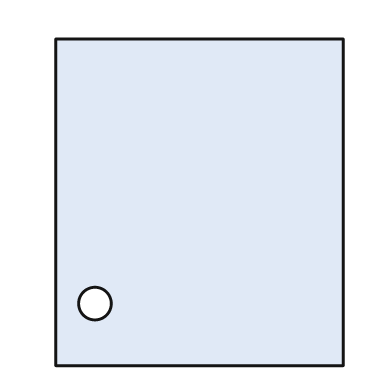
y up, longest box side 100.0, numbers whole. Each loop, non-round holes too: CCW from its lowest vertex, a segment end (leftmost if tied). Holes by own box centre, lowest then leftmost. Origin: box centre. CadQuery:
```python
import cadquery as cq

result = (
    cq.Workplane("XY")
    .moveTo(-44.0, -50.0)
    .lineTo(44.0, -50.0)
    .lineTo(44.0, 50.0)
    .lineTo(-44.0, 50.0)
    .close()
    .moveTo(-32.0, -31.0)
    .circle(5.0)
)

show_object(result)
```